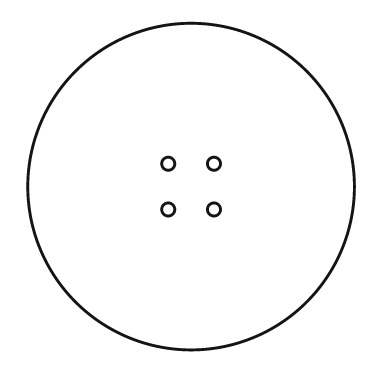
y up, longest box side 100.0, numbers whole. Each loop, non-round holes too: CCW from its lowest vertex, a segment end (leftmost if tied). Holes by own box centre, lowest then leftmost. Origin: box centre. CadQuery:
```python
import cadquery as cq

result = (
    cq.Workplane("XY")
    .moveTo(0.0, 0.0)
    .circle(50.0)
    .moveTo(-7.0, -7.0)
    .circle(2.0)
    .moveTo(7.0, -7.0)
    .circle(2.0)
    .moveTo(-7.0, 7.0)
    .circle(2.0)
    .moveTo(7.0, 7.0)
    .circle(2.0)
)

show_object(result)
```